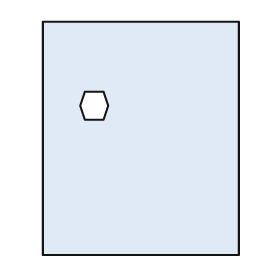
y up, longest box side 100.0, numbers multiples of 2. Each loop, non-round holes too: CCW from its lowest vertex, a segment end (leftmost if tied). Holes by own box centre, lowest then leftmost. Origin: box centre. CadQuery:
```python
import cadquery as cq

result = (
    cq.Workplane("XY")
    .moveTo(-42.0, -50.0)
    .lineTo(42.0, -50.0)
    .lineTo(42.0, 50.0)
    .lineTo(-42.0, 50.0)
    .close()
    .moveTo(-24.0, 8.0)
    .lineTo(-16.0, 8.0)
    .lineTo(-14.0, 14.0)
    .lineTo(-16.0, 20.0)
    .lineTo(-24.0, 20.0)
    .lineTo(-26.0, 14.0)
    .close()
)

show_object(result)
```